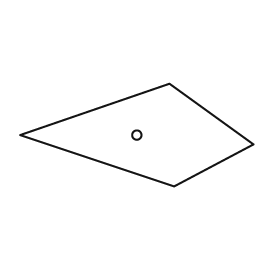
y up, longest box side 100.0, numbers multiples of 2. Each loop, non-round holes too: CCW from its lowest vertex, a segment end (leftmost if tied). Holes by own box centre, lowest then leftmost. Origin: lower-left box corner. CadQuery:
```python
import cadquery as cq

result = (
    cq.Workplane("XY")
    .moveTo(66.0, 0.0)
    .lineTo(100.0, 18.0)
    .lineTo(64.0, 44.0)
    .lineTo(0.0, 22.0)
    .close()
    .moveTo(50.0, 22.0)
    .circle(2.0)
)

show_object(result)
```